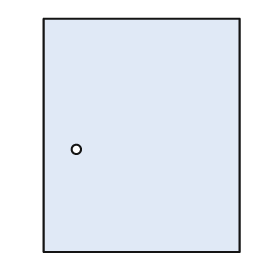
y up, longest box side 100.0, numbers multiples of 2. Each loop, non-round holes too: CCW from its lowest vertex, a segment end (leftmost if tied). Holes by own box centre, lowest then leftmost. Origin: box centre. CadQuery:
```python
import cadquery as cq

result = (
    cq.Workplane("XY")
    .moveTo(-42.0, -50.0)
    .lineTo(42.0, -50.0)
    .lineTo(42.0, 50.0)
    .lineTo(-42.0, 50.0)
    .close()
    .moveTo(-28.0, -6.0)
    .circle(2.0)
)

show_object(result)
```